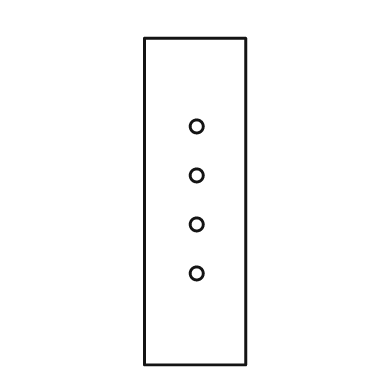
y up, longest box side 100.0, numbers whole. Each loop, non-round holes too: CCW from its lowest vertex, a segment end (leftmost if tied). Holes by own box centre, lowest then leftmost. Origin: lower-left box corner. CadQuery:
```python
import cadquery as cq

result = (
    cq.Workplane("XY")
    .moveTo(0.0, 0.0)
    .lineTo(31.0, 0.0)
    .lineTo(31.0, 100.0)
    .lineTo(0.0, 100.0)
    .close()
    .moveTo(16.0, 28.0)
    .circle(2.0)
    .moveTo(16.0, 43.0)
    .circle(2.0)
    .moveTo(16.0, 58.0)
    .circle(2.0)
    .moveTo(16.0, 73.0)
    .circle(2.0)
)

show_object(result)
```